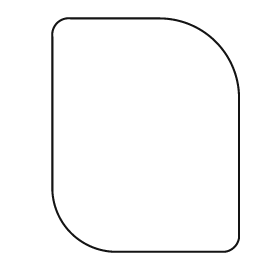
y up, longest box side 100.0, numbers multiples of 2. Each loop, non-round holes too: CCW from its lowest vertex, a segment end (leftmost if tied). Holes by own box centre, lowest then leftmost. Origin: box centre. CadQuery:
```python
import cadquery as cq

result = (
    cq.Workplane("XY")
    .moveTo(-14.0, -50.0)
    .lineTo(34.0, -50.0)
    .threePointArc((38.0, -48.0), (40.0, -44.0))
    .lineTo(40.0, 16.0)
    .threePointArc((30.0, 40.0), (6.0, 50.0))
    .lineTo(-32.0, 50.0)
    .threePointArc((-38.0, 48.0), (-40.0, 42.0))
    .lineTo(-40.0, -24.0)
    .threePointArc((-32.0, -42.0), (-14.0, -50.0))
    .close()
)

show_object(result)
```